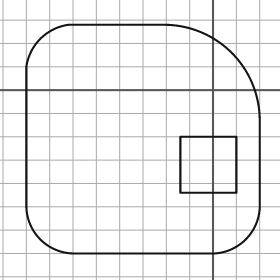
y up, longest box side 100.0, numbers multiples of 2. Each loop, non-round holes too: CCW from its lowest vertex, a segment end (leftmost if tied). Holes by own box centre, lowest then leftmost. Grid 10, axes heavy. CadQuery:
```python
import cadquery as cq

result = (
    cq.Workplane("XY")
    .moveTo(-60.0, -70.0)
    .lineTo(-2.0, -70.0)
    .threePointArc((14.0, -64.0), (20.0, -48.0))
    .lineTo(20.0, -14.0)
    .threePointArc((8.0, 16.0), (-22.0, 28.0))
    .lineTo(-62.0, 28.0)
    .threePointArc((-74.0, 22.0), (-80.0, 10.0))
    .lineTo(-80.0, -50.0)
    .threePointArc((-74.0, -64.0), (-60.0, -70.0))
    .close()
    .moveTo(-14.0, -44.0)
    .lineTo(10.0, -44.0)
    .lineTo(10.0, -20.0)
    .lineTo(-14.0, -20.0)
    .close()
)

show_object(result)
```